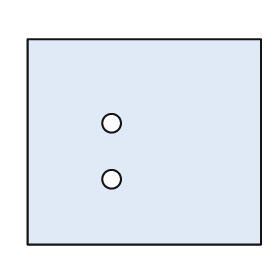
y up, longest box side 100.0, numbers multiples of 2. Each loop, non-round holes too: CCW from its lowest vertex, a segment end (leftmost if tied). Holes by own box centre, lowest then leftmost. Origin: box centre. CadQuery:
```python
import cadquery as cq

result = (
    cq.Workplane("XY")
    .moveTo(-50.0, -44.0)
    .lineTo(50.0, -44.0)
    .lineTo(50.0, 44.0)
    .lineTo(-50.0, 44.0)
    .close()
    .moveTo(-14.0, -16.0)
    .circle(4.0)
    .moveTo(-14.0, 8.0)
    .circle(4.0)
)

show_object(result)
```